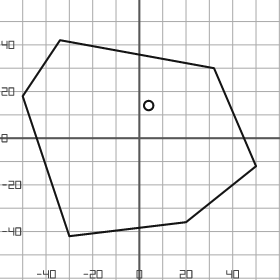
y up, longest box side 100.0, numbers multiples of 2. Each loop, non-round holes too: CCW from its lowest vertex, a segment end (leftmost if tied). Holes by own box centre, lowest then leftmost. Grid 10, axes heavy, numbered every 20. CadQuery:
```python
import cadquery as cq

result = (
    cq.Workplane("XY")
    .moveTo(-30.0, -42.0)
    .lineTo(20.0, -36.0)
    .lineTo(50.0, -12.0)
    .lineTo(32.0, 30.0)
    .lineTo(-34.0, 42.0)
    .lineTo(-50.0, 18.0)
    .close()
    .moveTo(4.0, 14.0)
    .circle(2.0)
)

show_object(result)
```